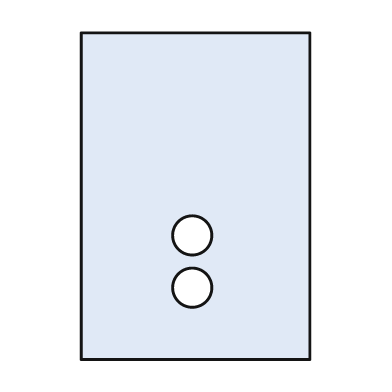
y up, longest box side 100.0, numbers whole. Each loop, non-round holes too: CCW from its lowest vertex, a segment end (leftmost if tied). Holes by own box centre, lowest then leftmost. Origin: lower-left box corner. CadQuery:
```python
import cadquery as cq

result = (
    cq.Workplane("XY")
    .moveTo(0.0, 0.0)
    .lineTo(70.0, 0.0)
    .lineTo(70.0, 100.0)
    .lineTo(0.0, 100.0)
    .close()
    .moveTo(34.0, 22.0)
    .circle(6.0)
    .moveTo(34.0, 38.0)
    .circle(6.0)
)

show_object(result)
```